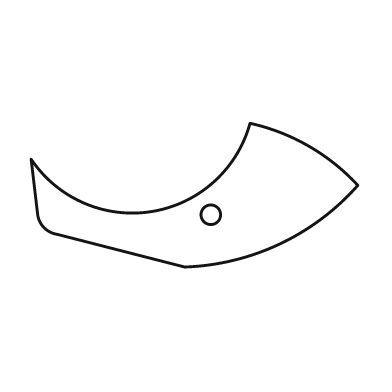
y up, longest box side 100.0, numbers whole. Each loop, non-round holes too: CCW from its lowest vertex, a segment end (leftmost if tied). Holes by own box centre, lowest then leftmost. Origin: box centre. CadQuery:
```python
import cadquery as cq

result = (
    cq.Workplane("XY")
    .moveTo(-3.0, -22.0)
    .threePointArc((26.0, -15.0), (50.0, 3.0))
    .threePointArc((35.0, 15.0), (17.0, 22.0))
    .threePointArc((-13.0, -5.0), (-50.0, 11.0))
    .lineTo(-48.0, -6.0)
    .threePointArc((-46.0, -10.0), (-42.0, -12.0))
    .close()
    .moveTo(5.0, -6.0)
    .circle(3.0)
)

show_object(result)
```